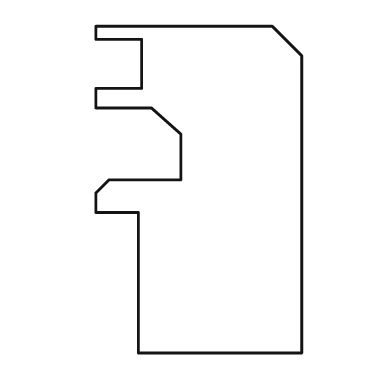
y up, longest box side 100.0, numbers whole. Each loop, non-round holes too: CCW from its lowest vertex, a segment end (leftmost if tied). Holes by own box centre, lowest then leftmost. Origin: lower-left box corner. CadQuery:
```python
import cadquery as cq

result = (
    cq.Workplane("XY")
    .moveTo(13.0, 0.0)
    .lineTo(63.0, 0.0)
    .lineTo(63.0, 91.0)
    .lineTo(54.0, 100.0)
    .lineTo(0.0, 100.0)
    .lineTo(0.0, 96.0)
    .lineTo(14.0, 96.0)
    .lineTo(14.0, 81.0)
    .lineTo(0.0, 81.0)
    .lineTo(0.0, 75.0)
    .lineTo(17.0, 75.0)
    .lineTo(26.0, 67.0)
    .lineTo(26.0, 53.0)
    .lineTo(4.0, 53.0)
    .lineTo(0.0, 49.0)
    .lineTo(0.0, 43.0)
    .lineTo(13.0, 43.0)
    .close()
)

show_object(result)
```